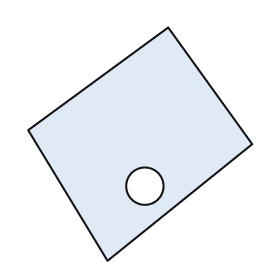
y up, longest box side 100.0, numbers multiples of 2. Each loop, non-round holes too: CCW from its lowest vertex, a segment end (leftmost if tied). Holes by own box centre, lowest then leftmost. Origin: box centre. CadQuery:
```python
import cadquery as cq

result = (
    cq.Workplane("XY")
    .moveTo(-14.0, -50.0)
    .lineTo(48.0, 0.0)
    .lineTo(12.0, 50.0)
    .lineTo(-48.0, 6.0)
    .close()
    .moveTo(2.0, -18.0)
    .circle(8.0)
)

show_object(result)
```